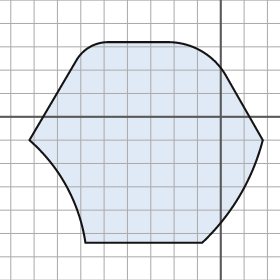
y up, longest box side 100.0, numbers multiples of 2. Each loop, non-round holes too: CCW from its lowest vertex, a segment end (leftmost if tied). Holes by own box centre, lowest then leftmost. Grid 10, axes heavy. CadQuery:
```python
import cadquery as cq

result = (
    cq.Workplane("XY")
    .moveTo(-58.0, -54.0)
    .lineTo(-8.0, -54.0)
    .threePointArc((8.0, -34.0), (18.0, -10.0))
    .lineTo(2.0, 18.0)
    .threePointArc((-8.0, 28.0), (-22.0, 32.0))
    .lineTo(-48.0, 32.0)
    .threePointArc((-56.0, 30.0), (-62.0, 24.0))
    .lineTo(-82.0, -10.0)
    .threePointArc((-66.0, -30.0), (-58.0, -54.0))
    .close()
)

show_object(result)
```